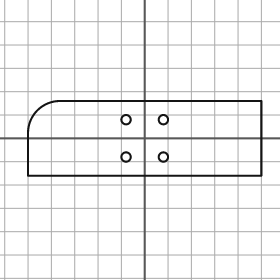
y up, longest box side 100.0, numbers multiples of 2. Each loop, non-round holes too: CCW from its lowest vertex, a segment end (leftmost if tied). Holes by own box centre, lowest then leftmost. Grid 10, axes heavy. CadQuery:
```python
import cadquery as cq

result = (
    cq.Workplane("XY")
    .moveTo(-50.0, -16.0)
    .lineTo(50.0, -16.0)
    .lineTo(50.0, 16.0)
    .lineTo(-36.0, 16.0)
    .threePointArc((-46.0, 12.0), (-50.0, 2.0))
    .close()
    .moveTo(-8.0, -8.0)
    .circle(2.0)
    .moveTo(8.0, -8.0)
    .circle(2.0)
    .moveTo(-8.0, 8.0)
    .circle(2.0)
    .moveTo(8.0, 8.0)
    .circle(2.0)
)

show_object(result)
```